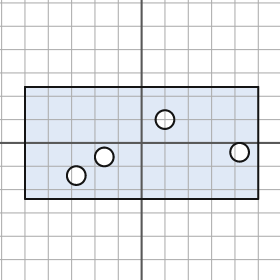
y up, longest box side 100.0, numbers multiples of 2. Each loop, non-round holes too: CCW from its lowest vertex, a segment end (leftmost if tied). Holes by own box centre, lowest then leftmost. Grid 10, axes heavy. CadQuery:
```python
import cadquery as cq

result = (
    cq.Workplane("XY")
    .moveTo(-50.0, -24.0)
    .lineTo(50.0, -24.0)
    .lineTo(50.0, 24.0)
    .lineTo(-50.0, 24.0)
    .close()
    .moveTo(-28.0, -14.0)
    .circle(4.0)
    .moveTo(-16.0, -6.0)
    .circle(4.0)
    .moveTo(42.0, -4.0)
    .circle(4.0)
    .moveTo(10.0, 10.0)
    .circle(4.0)
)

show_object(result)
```